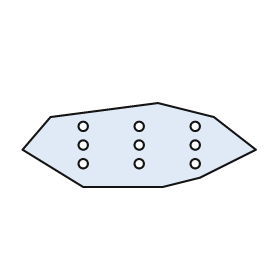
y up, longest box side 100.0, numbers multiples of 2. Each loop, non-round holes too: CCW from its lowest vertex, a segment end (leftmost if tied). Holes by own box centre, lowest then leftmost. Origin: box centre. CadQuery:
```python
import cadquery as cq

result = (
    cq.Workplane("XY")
    .moveTo(-24.0, -18.0)
    .lineTo(10.0, -18.0)
    .lineTo(26.0, -14.0)
    .lineTo(50.0, -2.0)
    .lineTo(32.0, 12.0)
    .lineTo(8.0, 18.0)
    .lineTo(-38.0, 12.0)
    .lineTo(-50.0, -2.0)
    .close()
    .moveTo(-24.0, -8.0)
    .circle(2.0)
    .moveTo(0.0, -8.0)
    .circle(2.0)
    .moveTo(24.0, -8.0)
    .circle(2.0)
    .moveTo(-24.0, 0.0)
    .circle(2.0)
    .moveTo(0.0, 0.0)
    .circle(2.0)
    .moveTo(24.0, 0.0)
    .circle(2.0)
    .moveTo(-24.0, 8.0)
    .circle(2.0)
    .moveTo(0.0, 8.0)
    .circle(2.0)
    .moveTo(24.0, 8.0)
    .circle(2.0)
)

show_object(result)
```